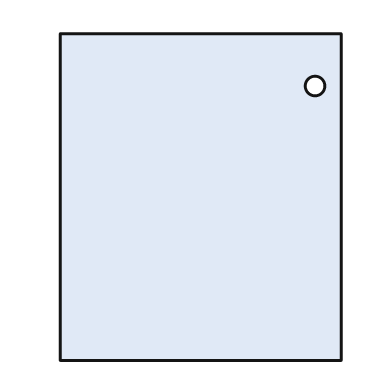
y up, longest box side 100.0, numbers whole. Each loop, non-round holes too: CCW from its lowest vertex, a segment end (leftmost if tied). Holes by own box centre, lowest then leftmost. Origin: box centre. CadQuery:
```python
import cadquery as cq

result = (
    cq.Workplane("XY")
    .moveTo(-43.0, -50.0)
    .lineTo(43.0, -50.0)
    .lineTo(43.0, 50.0)
    .lineTo(-43.0, 50.0)
    .close()
    .moveTo(35.0, 34.0)
    .circle(3.0)
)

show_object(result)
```